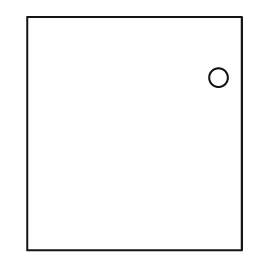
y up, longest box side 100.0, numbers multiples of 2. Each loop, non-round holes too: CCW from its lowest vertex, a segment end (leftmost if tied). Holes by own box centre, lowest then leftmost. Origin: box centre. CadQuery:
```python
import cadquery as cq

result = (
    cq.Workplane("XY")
    .moveTo(-46.0, -50.0)
    .lineTo(46.0, -50.0)
    .lineTo(46.0, 50.0)
    .lineTo(-46.0, 50.0)
    .close()
    .moveTo(36.0, 24.0)
    .circle(4.0)
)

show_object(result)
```